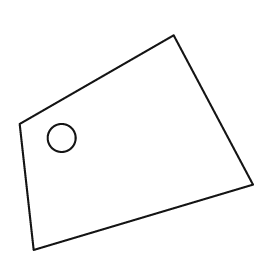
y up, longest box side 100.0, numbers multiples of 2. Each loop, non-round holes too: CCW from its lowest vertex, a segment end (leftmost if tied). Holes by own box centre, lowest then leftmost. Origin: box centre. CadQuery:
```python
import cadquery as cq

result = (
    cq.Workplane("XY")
    .moveTo(-44.0, -46.0)
    .lineTo(50.0, -18.0)
    .lineTo(16.0, 46.0)
    .lineTo(-50.0, 8.0)
    .close()
    .moveTo(-32.0, 2.0)
    .circle(6.0)
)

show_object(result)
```